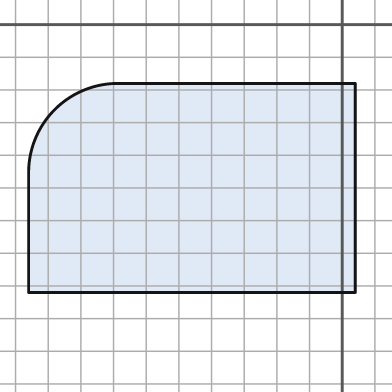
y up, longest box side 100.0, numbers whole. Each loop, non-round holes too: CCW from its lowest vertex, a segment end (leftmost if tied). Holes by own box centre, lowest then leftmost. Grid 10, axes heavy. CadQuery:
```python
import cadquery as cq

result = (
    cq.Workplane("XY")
    .moveTo(-96.0, -82.0)
    .lineTo(4.0, -82.0)
    .lineTo(4.0, -18.0)
    .lineTo(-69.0, -18.0)
    .threePointArc((-88.0, -26.0), (-96.0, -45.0))
    .close()
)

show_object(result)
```